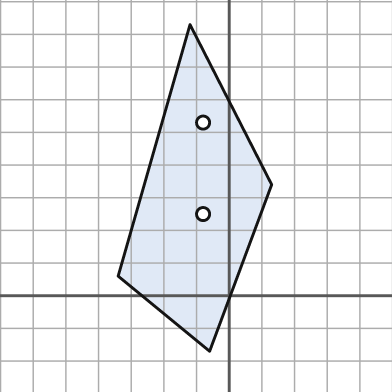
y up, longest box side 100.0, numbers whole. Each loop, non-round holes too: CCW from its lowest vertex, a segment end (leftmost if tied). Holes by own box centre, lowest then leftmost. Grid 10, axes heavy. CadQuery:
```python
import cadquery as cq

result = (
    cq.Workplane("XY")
    .moveTo(-6.0, -17.0)
    .lineTo(13.0, 34.0)
    .lineTo(-12.0, 83.0)
    .lineTo(-34.0, 6.0)
    .close()
    .moveTo(-8.0, 25.0)
    .circle(2.0)
    .moveTo(-8.0, 53.0)
    .circle(2.0)
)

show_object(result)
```